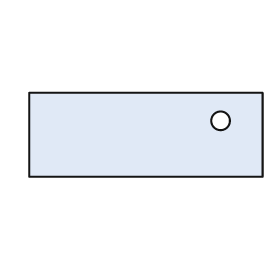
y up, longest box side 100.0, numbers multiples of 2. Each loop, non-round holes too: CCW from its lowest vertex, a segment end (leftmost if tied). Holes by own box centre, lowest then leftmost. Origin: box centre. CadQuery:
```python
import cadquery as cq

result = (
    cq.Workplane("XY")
    .moveTo(-50.0, -18.0)
    .lineTo(50.0, -18.0)
    .lineTo(50.0, 18.0)
    .lineTo(-50.0, 18.0)
    .close()
    .moveTo(32.0, 6.0)
    .circle(4.0)
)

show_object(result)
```